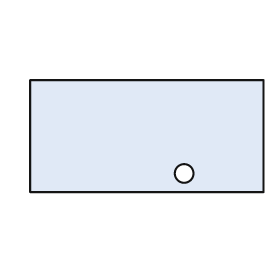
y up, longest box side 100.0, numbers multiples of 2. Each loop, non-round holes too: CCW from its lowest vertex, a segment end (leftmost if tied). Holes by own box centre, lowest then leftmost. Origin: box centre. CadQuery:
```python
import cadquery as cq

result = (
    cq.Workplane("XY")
    .moveTo(-50.0, -24.0)
    .lineTo(50.0, -24.0)
    .lineTo(50.0, 24.0)
    .lineTo(-50.0, 24.0)
    .close()
    .moveTo(16.0, -16.0)
    .circle(4.0)
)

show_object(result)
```